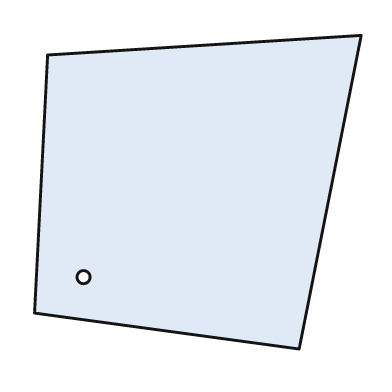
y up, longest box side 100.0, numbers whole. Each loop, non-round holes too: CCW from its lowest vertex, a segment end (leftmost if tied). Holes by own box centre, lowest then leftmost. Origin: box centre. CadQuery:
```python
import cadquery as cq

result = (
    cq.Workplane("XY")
    .moveTo(31.0, -48.0)
    .lineTo(50.0, 48.0)
    .lineTo(-46.0, 42.0)
    .lineTo(-50.0, -37.0)
    .close()
    .moveTo(-35.0, -26.0)
    .circle(2.0)
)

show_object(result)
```